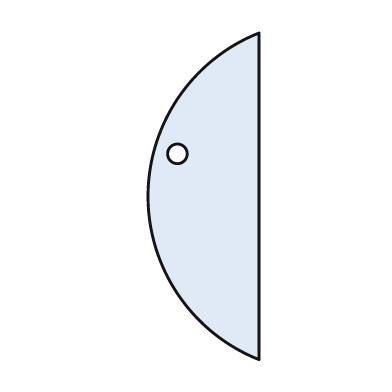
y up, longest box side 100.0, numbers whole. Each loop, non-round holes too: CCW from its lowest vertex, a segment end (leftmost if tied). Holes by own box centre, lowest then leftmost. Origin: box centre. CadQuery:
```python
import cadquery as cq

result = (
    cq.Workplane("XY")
    .moveTo(17.0, -50.0)
    .lineTo(17.0, 50.0)
    .threePointArc((-17.0, 0.0), (17.0, -50.0))
    .close()
    .moveTo(-8.0, 13.0)
    .circle(3.0)
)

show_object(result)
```